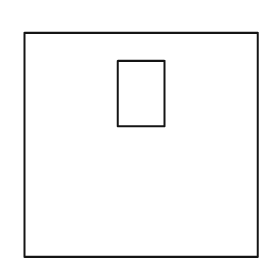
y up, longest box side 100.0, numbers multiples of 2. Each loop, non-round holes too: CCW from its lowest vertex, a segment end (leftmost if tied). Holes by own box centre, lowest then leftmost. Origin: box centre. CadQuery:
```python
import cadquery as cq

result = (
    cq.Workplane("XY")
    .moveTo(-50.0, -48.0)
    .lineTo(50.0, -48.0)
    .lineTo(50.0, 48.0)
    .lineTo(-50.0, 48.0)
    .close()
    .moveTo(-10.0, 8.0)
    .lineTo(10.0, 8.0)
    .lineTo(10.0, 36.0)
    .lineTo(-10.0, 36.0)
    .close()
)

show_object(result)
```